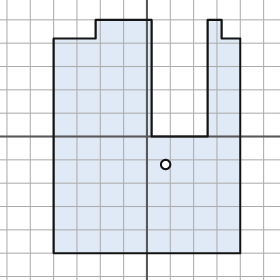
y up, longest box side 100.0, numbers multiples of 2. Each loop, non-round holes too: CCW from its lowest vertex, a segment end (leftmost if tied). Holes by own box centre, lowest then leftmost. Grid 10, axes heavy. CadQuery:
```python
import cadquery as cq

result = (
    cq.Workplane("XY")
    .moveTo(-40.0, -50.0)
    .lineTo(40.0, -50.0)
    .lineTo(40.0, 42.0)
    .lineTo(32.0, 42.0)
    .lineTo(32.0, 50.0)
    .lineTo(26.0, 50.0)
    .lineTo(26.0, 0.0)
    .lineTo(2.0, 0.0)
    .lineTo(2.0, 50.0)
    .lineTo(-22.0, 50.0)
    .lineTo(-22.0, 42.0)
    .lineTo(-40.0, 42.0)
    .close()
    .moveTo(8.0, -12.0)
    .circle(2.0)
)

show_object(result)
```